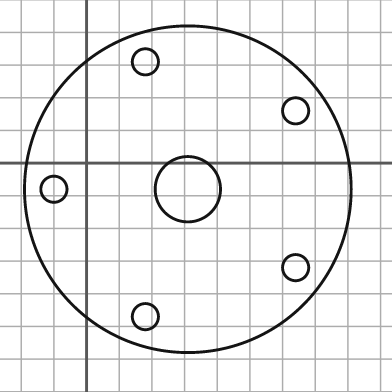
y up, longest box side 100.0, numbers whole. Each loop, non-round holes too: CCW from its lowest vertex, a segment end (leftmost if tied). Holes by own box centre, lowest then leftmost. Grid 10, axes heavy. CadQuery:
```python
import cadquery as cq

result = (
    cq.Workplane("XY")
    .moveTo(31.0, -8.0)
    .circle(50.0)
    .moveTo(18.0, -47.0)
    .circle(4.0)
    .moveTo(64.0, -32.0)
    .circle(4.0)
    .moveTo(-10.0, -8.0)
    .circle(4.0)
    .moveTo(31.0, -8.0)
    .circle(10.0)
    .moveTo(64.0, 16.0)
    .circle(4.0)
    .moveTo(18.0, 31.0)
    .circle(4.0)
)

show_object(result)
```